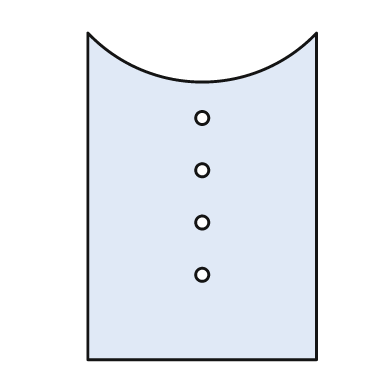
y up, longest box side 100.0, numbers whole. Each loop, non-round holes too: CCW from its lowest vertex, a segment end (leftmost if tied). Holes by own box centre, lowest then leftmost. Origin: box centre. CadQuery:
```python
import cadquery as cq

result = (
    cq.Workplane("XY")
    .moveTo(-35.0, -50.0)
    .lineTo(35.0, -50.0)
    .lineTo(35.0, 50.0)
    .threePointArc((0.0, 35.0), (-35.0, 50.0))
    .close()
    .moveTo(0.0, -24.0)
    .circle(2.0)
    .moveTo(0.0, -8.0)
    .circle(2.0)
    .moveTo(0.0, 8.0)
    .circle(2.0)
    .moveTo(0.0, 24.0)
    .circle(2.0)
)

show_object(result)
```